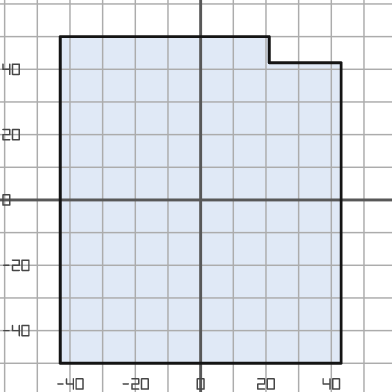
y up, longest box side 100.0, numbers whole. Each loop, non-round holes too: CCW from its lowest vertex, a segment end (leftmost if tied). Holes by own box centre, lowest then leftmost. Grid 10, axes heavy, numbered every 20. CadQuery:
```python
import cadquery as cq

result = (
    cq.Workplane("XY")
    .moveTo(-43.0, -50.0)
    .lineTo(43.0, -50.0)
    .lineTo(43.0, 42.0)
    .lineTo(21.0, 42.0)
    .lineTo(21.0, 50.0)
    .lineTo(-43.0, 50.0)
    .close()
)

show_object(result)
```